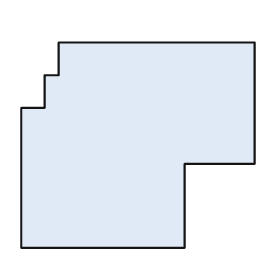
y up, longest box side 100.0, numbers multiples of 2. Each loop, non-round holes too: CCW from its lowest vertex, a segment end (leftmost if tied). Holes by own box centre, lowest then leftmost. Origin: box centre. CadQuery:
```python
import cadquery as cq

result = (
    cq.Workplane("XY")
    .moveTo(-50.0, -44.0)
    .lineTo(20.0, -44.0)
    .lineTo(20.0, -8.0)
    .lineTo(50.0, -8.0)
    .lineTo(50.0, 44.0)
    .lineTo(-34.0, 44.0)
    .lineTo(-34.0, 30.0)
    .lineTo(-40.0, 30.0)
    .lineTo(-40.0, 16.0)
    .lineTo(-50.0, 16.0)
    .close()
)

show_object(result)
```